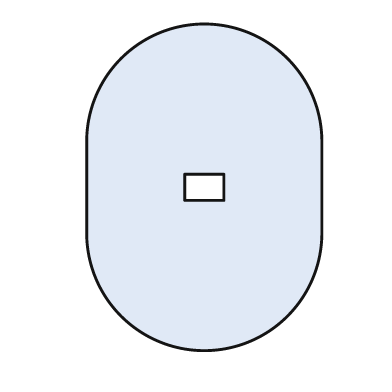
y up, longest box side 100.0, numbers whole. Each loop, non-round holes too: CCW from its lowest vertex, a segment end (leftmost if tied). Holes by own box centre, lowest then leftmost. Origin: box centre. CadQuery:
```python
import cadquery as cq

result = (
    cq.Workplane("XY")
    .moveTo(-36.0, -14.0)
    .threePointArc((0.0, -50.0), (36.0, -14.0))
    .lineTo(36.0, 14.0)
    .threePointArc((0.0, 50.0), (-36.0, 14.0))
    .close()
    .moveTo(-6.0, -4.0)
    .lineTo(6.0, -4.0)
    .lineTo(6.0, 4.0)
    .lineTo(-6.0, 4.0)
    .close()
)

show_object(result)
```